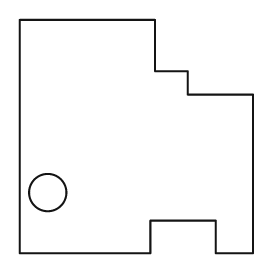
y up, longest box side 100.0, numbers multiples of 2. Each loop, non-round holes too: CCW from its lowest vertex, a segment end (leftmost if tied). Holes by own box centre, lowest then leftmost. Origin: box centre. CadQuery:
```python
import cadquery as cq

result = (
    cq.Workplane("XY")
    .moveTo(-50.0, -50.0)
    .lineTo(6.0, -50.0)
    .lineTo(6.0, -36.0)
    .lineTo(34.0, -36.0)
    .lineTo(34.0, -50.0)
    .lineTo(50.0, -50.0)
    .lineTo(50.0, 18.0)
    .lineTo(22.0, 18.0)
    .lineTo(22.0, 28.0)
    .lineTo(8.0, 28.0)
    .lineTo(8.0, 50.0)
    .lineTo(-50.0, 50.0)
    .close()
    .moveTo(-38.0, -24.0)
    .circle(8.0)
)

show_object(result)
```